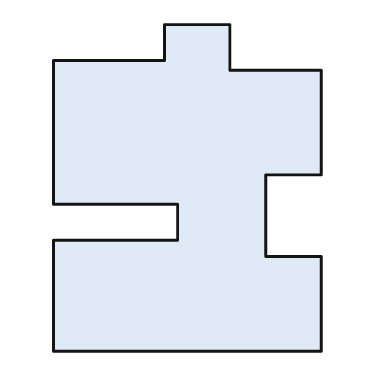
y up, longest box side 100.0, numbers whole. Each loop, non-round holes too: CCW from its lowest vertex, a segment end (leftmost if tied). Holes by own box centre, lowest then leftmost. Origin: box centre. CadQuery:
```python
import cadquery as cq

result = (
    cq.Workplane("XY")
    .moveTo(-41.0, -50.0)
    .lineTo(41.0, -50.0)
    .lineTo(41.0, -21.0)
    .lineTo(24.0, -21.0)
    .lineTo(24.0, 4.0)
    .lineTo(41.0, 4.0)
    .lineTo(41.0, 36.0)
    .lineTo(13.0, 36.0)
    .lineTo(13.0, 50.0)
    .lineTo(-7.0, 50.0)
    .lineTo(-7.0, 39.0)
    .lineTo(-41.0, 39.0)
    .lineTo(-41.0, -5.0)
    .lineTo(-3.0, -5.0)
    .lineTo(-3.0, -16.0)
    .lineTo(-41.0, -16.0)
    .close()
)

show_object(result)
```